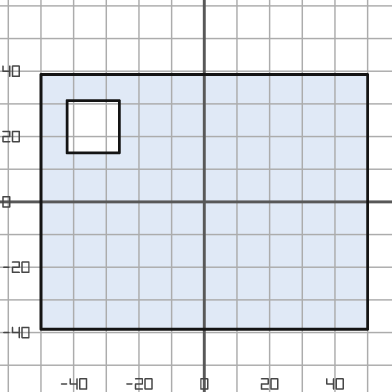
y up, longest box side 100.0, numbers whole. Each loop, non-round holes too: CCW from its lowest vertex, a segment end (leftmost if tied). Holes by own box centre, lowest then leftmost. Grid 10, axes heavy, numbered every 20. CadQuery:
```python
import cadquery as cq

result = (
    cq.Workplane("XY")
    .moveTo(-50.0, -39.0)
    .lineTo(50.0, -39.0)
    .lineTo(50.0, 39.0)
    .lineTo(-50.0, 39.0)
    .close()
    .moveTo(-42.0, 15.0)
    .lineTo(-26.0, 15.0)
    .lineTo(-26.0, 31.0)
    .lineTo(-42.0, 31.0)
    .close()
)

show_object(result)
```